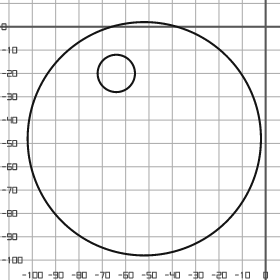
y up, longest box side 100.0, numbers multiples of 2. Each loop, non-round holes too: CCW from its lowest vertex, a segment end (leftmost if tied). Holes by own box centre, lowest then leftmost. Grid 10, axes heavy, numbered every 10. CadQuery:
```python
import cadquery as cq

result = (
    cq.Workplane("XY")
    .moveTo(-52.0, -48.0)
    .circle(50.0)
    .moveTo(-64.0, -20.0)
    .circle(8.0)
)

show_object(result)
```